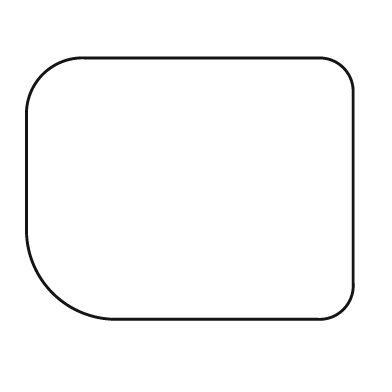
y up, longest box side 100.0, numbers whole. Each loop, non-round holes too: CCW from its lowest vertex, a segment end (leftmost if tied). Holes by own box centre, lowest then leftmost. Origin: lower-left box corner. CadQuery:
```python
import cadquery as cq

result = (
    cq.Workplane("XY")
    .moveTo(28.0, 0.0)
    .lineTo(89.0, 0.0)
    .threePointArc((97.0, 3.0), (100.0, 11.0))
    .lineTo(100.0, 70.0)
    .threePointArc((97.0, 77.0), (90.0, 80.0))
    .lineTo(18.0, 80.0)
    .threePointArc((5.0, 75.0), (0.0, 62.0))
    .lineTo(0.0, 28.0)
    .threePointArc((8.0, 8.0), (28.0, 0.0))
    .close()
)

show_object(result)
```